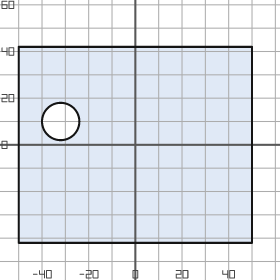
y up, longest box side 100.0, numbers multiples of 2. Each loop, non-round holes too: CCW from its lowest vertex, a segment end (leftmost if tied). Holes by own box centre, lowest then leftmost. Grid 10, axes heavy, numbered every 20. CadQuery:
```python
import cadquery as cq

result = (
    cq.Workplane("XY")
    .moveTo(-50.0, -42.0)
    .lineTo(50.0, -42.0)
    .lineTo(50.0, 42.0)
    .lineTo(-50.0, 42.0)
    .close()
    .moveTo(-32.0, 10.0)
    .circle(8.0)
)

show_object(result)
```